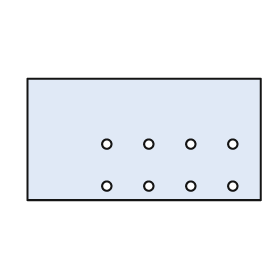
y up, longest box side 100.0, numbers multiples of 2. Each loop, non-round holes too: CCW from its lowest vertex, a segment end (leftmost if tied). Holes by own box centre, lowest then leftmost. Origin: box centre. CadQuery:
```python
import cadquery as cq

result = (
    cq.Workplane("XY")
    .moveTo(-50.0, -26.0)
    .lineTo(50.0, -26.0)
    .lineTo(50.0, 26.0)
    .lineTo(-50.0, 26.0)
    .close()
    .moveTo(-16.0, -20.0)
    .circle(2.0)
    .moveTo(2.0, -20.0)
    .circle(2.0)
    .moveTo(20.0, -20.0)
    .circle(2.0)
    .moveTo(38.0, -20.0)
    .circle(2.0)
    .moveTo(-16.0, -2.0)
    .circle(2.0)
    .moveTo(2.0, -2.0)
    .circle(2.0)
    .moveTo(20.0, -2.0)
    .circle(2.0)
    .moveTo(38.0, -2.0)
    .circle(2.0)
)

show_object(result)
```